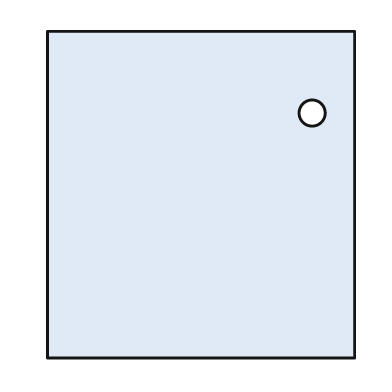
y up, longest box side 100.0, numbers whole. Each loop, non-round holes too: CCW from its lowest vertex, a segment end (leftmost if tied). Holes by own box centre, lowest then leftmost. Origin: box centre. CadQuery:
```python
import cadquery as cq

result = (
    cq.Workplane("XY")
    .moveTo(-47.0, -50.0)
    .lineTo(47.0, -50.0)
    .lineTo(47.0, 50.0)
    .lineTo(-47.0, 50.0)
    .close()
    .moveTo(34.0, 25.0)
    .circle(4.0)
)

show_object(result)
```